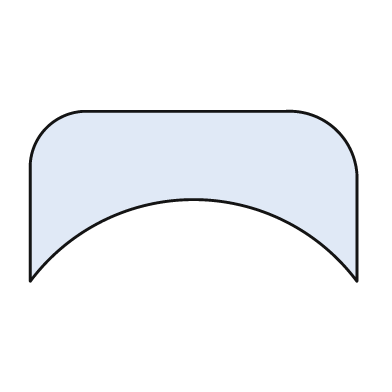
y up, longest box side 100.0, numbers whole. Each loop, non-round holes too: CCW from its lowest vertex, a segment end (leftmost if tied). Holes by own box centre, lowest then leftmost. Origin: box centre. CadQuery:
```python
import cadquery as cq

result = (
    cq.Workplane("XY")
    .moveTo(-50.0, -26.0)
    .threePointArc((0.0, -1.0), (50.0, -26.0))
    .lineTo(50.0, 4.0)
    .threePointArc((44.0, 20.0), (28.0, 26.0))
    .lineTo(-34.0, 26.0)
    .threePointArc((-45.0, 21.0), (-50.0, 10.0))
    .close()
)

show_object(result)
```